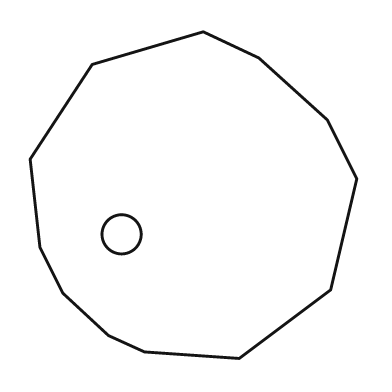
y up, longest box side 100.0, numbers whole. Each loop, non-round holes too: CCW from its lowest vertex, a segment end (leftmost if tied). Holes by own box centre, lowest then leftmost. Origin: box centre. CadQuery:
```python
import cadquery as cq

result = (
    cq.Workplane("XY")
    .moveTo(14.0, -50.0)
    .lineTo(42.0, -29.0)
    .lineTo(50.0, 5.0)
    .lineTo(41.0, 23.0)
    .lineTo(20.0, 42.0)
    .lineTo(3.0, 50.0)
    .lineTo(-31.0, 40.0)
    .lineTo(-50.0, 11.0)
    .lineTo(-47.0, -16.0)
    .lineTo(-40.0, -30.0)
    .lineTo(-26.0, -43.0)
    .lineTo(-15.0, -48.0)
    .close()
    .moveTo(-22.0, -12.0)
    .circle(6.0)
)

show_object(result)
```